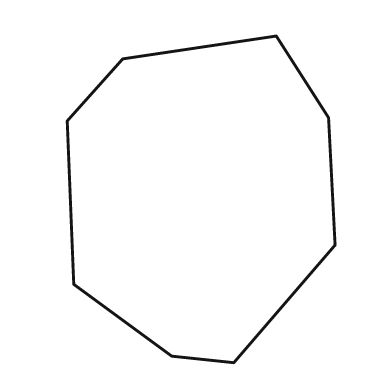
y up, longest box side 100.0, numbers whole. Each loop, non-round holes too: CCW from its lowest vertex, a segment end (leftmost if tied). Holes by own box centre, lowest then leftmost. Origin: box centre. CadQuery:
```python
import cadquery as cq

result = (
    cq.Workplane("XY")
    .moveTo(10.0, -50.0)
    .lineTo(41.0, -14.0)
    .lineTo(39.0, 25.0)
    .lineTo(23.0, 50.0)
    .lineTo(-24.0, 43.0)
    .lineTo(-41.0, 24.0)
    .lineTo(-39.0, -26.0)
    .lineTo(-9.0, -48.0)
    .close()
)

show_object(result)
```